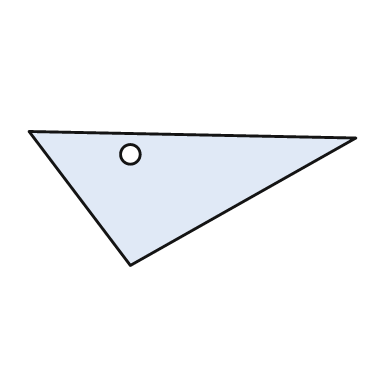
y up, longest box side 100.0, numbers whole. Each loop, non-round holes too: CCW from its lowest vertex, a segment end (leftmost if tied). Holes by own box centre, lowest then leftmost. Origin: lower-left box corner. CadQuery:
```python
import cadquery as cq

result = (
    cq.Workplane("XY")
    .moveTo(31.0, 0.0)
    .lineTo(100.0, 39.0)
    .lineTo(0.0, 41.0)
    .close()
    .moveTo(31.0, 34.0)
    .circle(3.0)
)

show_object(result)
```